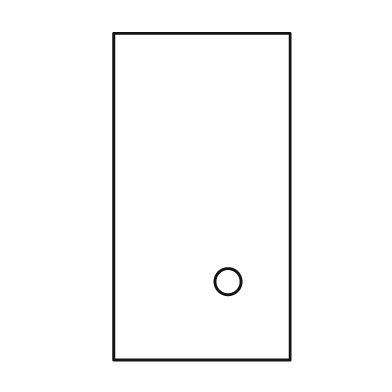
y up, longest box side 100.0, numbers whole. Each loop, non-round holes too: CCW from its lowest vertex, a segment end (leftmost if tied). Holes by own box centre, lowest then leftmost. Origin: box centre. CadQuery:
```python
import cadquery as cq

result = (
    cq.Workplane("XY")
    .moveTo(-27.0, -50.0)
    .lineTo(27.0, -50.0)
    .lineTo(27.0, 50.0)
    .lineTo(-27.0, 50.0)
    .close()
    .moveTo(8.0, -26.0)
    .circle(4.0)
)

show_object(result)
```